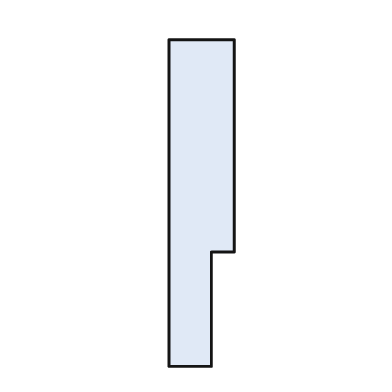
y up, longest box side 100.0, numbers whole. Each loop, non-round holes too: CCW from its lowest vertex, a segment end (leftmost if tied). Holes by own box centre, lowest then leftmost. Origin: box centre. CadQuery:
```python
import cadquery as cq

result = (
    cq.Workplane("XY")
    .moveTo(-10.0, -50.0)
    .lineTo(3.0, -50.0)
    .lineTo(3.0, -15.0)
    .lineTo(10.0, -15.0)
    .lineTo(10.0, 50.0)
    .lineTo(-10.0, 50.0)
    .close()
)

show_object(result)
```